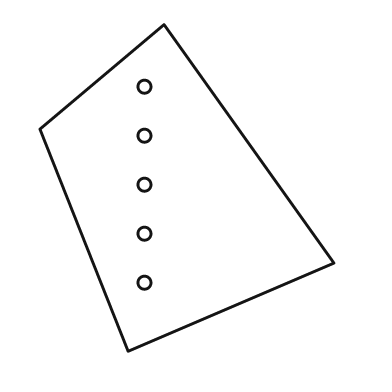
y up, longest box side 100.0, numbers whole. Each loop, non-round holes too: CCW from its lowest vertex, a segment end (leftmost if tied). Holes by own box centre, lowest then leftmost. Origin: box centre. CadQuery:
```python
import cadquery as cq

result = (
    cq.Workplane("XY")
    .moveTo(-18.0, -50.0)
    .lineTo(45.0, -23.0)
    .lineTo(-7.0, 50.0)
    .lineTo(-45.0, 18.0)
    .close()
    .moveTo(-13.0, -29.0)
    .circle(2.0)
    .moveTo(-13.0, -14.0)
    .circle(2.0)
    .moveTo(-13.0, 1.0)
    .circle(2.0)
    .moveTo(-13.0, 16.0)
    .circle(2.0)
    .moveTo(-13.0, 31.0)
    .circle(2.0)
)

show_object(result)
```